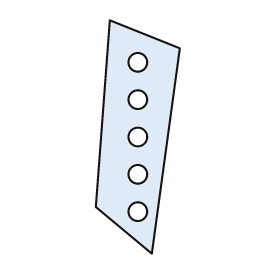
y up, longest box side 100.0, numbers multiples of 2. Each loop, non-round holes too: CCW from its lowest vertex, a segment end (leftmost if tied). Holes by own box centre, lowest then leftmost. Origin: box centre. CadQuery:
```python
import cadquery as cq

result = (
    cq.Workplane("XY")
    .moveTo(6.0, -50.0)
    .lineTo(18.0, 38.0)
    .lineTo(-12.0, 50.0)
    .lineTo(-18.0, -30.0)
    .close()
    .moveTo(0.0, -32.0)
    .circle(4.0)
    .moveTo(0.0, -16.0)
    .circle(4.0)
    .moveTo(0.0, 0.0)
    .circle(4.0)
    .moveTo(0.0, 16.0)
    .circle(4.0)
    .moveTo(0.0, 32.0)
    .circle(4.0)
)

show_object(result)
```